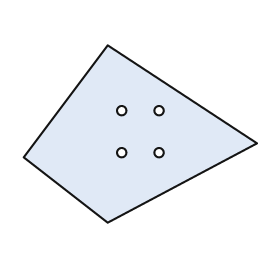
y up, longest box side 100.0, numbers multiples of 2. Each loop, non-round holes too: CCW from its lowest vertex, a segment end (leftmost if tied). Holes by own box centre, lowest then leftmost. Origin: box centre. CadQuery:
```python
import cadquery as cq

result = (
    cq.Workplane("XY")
    .moveTo(-14.0, -38.0)
    .lineTo(50.0, -4.0)
    .lineTo(-14.0, 38.0)
    .lineTo(-50.0, -10.0)
    .close()
    .moveTo(-8.0, -8.0)
    .circle(2.0)
    .moveTo(8.0, -8.0)
    .circle(2.0)
    .moveTo(-8.0, 10.0)
    .circle(2.0)
    .moveTo(8.0, 10.0)
    .circle(2.0)
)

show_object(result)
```